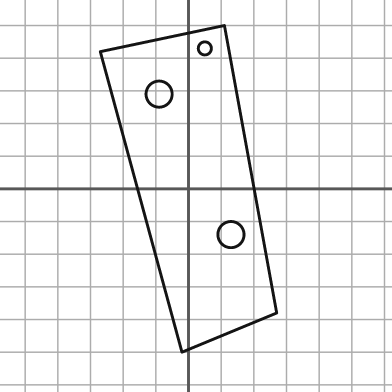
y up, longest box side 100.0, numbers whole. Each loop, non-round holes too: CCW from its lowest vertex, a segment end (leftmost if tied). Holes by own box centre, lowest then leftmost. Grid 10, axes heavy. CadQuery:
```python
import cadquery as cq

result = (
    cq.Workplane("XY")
    .moveTo(-2.0, -50.0)
    .lineTo(27.0, -38.0)
    .lineTo(11.0, 50.0)
    .lineTo(-27.0, 42.0)
    .close()
    .moveTo(13.0, -14.0)
    .circle(4.0)
    .moveTo(-9.0, 29.0)
    .circle(4.0)
    .moveTo(5.0, 43.0)
    .circle(2.0)
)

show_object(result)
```